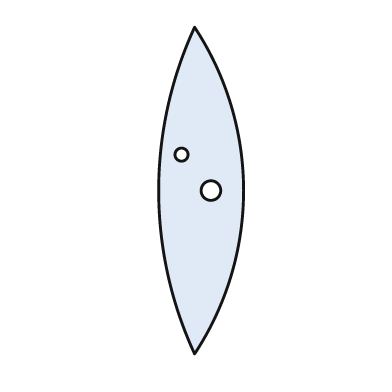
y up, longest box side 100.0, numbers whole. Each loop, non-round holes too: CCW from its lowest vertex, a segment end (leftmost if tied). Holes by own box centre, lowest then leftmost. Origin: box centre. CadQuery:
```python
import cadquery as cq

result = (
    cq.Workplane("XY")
    .moveTo(-2.0, -50.0)
    .threePointArc((13.0, 0.0), (-2.0, 50.0))
    .threePointArc((-13.0, 0.0), (-2.0, -50.0))
    .close()
    .moveTo(3.0, 0.0)
    .circle(3.0)
    .moveTo(-6.0, 11.0)
    .circle(2.0)
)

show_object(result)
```